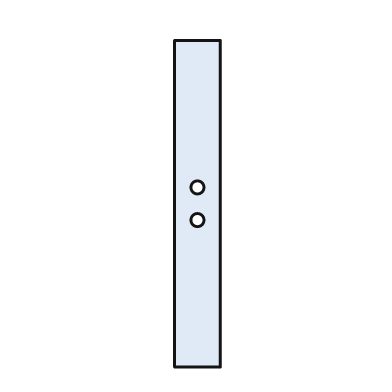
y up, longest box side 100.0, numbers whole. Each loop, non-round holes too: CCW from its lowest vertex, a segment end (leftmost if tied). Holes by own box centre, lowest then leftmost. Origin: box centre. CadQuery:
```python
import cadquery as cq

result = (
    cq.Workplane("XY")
    .moveTo(-7.0, -50.0)
    .lineTo(7.0, -50.0)
    .lineTo(7.0, 50.0)
    .lineTo(-7.0, 50.0)
    .close()
    .moveTo(0.0, -5.0)
    .circle(2.0)
    .moveTo(0.0, 5.0)
    .circle(2.0)
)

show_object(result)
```